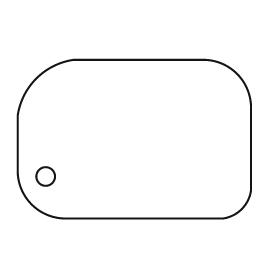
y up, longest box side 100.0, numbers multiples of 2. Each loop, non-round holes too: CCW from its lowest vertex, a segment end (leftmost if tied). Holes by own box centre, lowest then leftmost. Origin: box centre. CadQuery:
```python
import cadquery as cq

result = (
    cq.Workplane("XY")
    .moveTo(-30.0, -34.0)
    .lineTo(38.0, -34.0)
    .threePointArc((46.0, -30.0), (50.0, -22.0))
    .lineTo(50.0, 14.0)
    .threePointArc((44.0, 28.0), (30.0, 34.0))
    .lineTo(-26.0, 34.0)
    .threePointArc((-42.0, 26.0), (-50.0, 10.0))
    .lineTo(-50.0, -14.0)
    .threePointArc((-44.0, -28.0), (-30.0, -34.0))
    .close()
    .moveTo(-38.0, -16.0)
    .circle(4.0)
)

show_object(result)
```